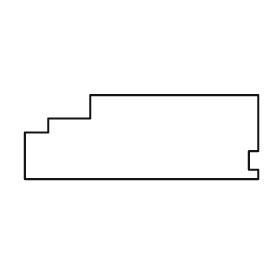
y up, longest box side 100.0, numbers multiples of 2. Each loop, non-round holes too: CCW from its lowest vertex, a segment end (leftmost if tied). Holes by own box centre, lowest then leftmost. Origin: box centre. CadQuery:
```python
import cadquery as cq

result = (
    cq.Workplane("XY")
    .moveTo(-50.0, -18.0)
    .lineTo(50.0, -18.0)
    .lineTo(50.0, -14.0)
    .lineTo(46.0, -14.0)
    .lineTo(46.0, -6.0)
    .lineTo(50.0, -6.0)
    .lineTo(50.0, 18.0)
    .lineTo(-22.0, 18.0)
    .lineTo(-22.0, 8.0)
    .lineTo(-40.0, 8.0)
    .lineTo(-40.0, 2.0)
    .lineTo(-50.0, 2.0)
    .close()
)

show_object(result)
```